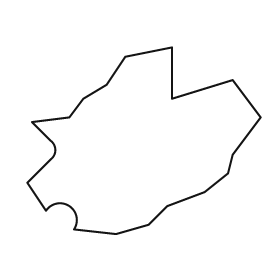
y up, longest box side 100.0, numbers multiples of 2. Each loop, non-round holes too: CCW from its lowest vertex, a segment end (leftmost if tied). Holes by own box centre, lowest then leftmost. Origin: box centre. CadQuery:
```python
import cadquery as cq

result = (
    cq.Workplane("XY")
    .moveTo(-12.0, -40.0)
    .lineTo(2.0, -36.0)
    .lineTo(10.0, -28.0)
    .lineTo(26.0, -22.0)
    .lineTo(36.0, -14.0)
    .lineTo(38.0, -6.0)
    .lineTo(50.0, 10.0)
    .lineTo(38.0, 26.0)
    .lineTo(12.0, 18.0)
    .lineTo(12.0, 40.0)
    .lineTo(-8.0, 36.0)
    .lineTo(-16.0, 24.0)
    .lineTo(-26.0, 18.0)
    .lineTo(-32.0, 10.0)
    .lineTo(-48.0, 8.0)
    .lineTo(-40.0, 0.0)
    .threePointArc((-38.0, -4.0), (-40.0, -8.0))
    .lineTo(-50.0, -18.0)
    .lineTo(-42.0, -30.0)
    .threePointArc((-32.0, -28.0), (-30.0, -38.0))
    .close()
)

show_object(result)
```